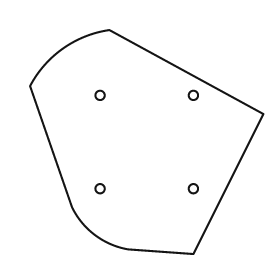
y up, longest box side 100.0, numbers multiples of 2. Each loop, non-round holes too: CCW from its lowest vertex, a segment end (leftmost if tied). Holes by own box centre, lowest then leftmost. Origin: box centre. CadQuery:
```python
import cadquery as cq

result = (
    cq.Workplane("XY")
    .moveTo(20.0, -48.0)
    .lineTo(50.0, 12.0)
    .lineTo(-16.0, 48.0)
    .threePointArc((-36.0, 40.0), (-50.0, 24.0))
    .lineTo(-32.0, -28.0)
    .threePointArc((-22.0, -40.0), (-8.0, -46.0))
    .close()
    .moveTo(-20.0, -20.0)
    .circle(2.0)
    .moveTo(20.0, -20.0)
    .circle(2.0)
    .moveTo(-20.0, 20.0)
    .circle(2.0)
    .moveTo(20.0, 20.0)
    .circle(2.0)
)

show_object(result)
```